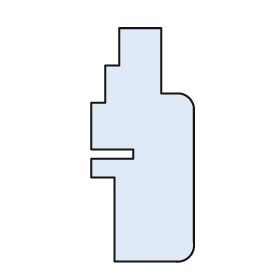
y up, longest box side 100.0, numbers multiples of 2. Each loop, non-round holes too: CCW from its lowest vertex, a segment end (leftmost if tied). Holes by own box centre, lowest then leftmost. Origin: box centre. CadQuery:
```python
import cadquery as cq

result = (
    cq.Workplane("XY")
    .moveTo(-12.0, -50.0)
    .lineTo(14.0, -50.0)
    .threePointArc((20.0, -48.0), (22.0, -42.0))
    .lineTo(22.0, 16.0)
    .threePointArc((20.0, 20.0), (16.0, 22.0))
    .lineTo(8.0, 22.0)
    .lineTo(8.0, 50.0)
    .lineTo(-10.0, 50.0)
    .lineTo(-10.0, 34.0)
    .lineTo(-16.0, 34.0)
    .lineTo(-16.0, 18.0)
    .lineTo(-22.0, 18.0)
    .lineTo(-22.0, -2.0)
    .lineTo(-4.0, -2.0)
    .lineTo(-4.0, -6.0)
    .lineTo(-22.0, -6.0)
    .lineTo(-22.0, -14.0)
    .lineTo(-12.0, -14.0)
    .close()
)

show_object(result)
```